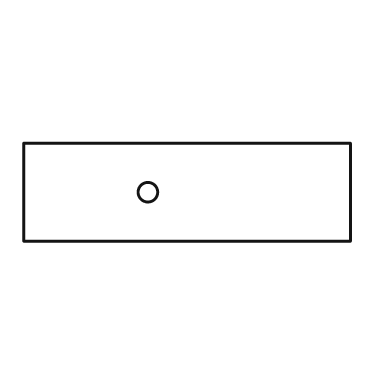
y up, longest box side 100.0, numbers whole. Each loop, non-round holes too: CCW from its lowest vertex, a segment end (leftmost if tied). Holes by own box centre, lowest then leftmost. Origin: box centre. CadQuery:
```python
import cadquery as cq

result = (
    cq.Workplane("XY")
    .moveTo(-50.0, -15.0)
    .lineTo(50.0, -15.0)
    .lineTo(50.0, 15.0)
    .lineTo(-50.0, 15.0)
    .close()
    .moveTo(-12.0, 0.0)
    .circle(3.0)
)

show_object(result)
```